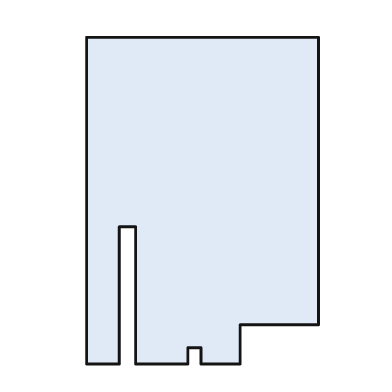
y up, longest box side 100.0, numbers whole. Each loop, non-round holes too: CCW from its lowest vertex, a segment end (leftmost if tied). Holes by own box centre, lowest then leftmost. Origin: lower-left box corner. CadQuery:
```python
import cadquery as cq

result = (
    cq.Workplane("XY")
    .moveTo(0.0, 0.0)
    .lineTo(10.0, 0.0)
    .lineTo(10.0, 42.0)
    .lineTo(15.0, 42.0)
    .lineTo(15.0, 0.0)
    .lineTo(31.0, 0.0)
    .lineTo(31.0, 5.0)
    .lineTo(35.0, 5.0)
    .lineTo(35.0, 0.0)
    .lineTo(47.0, 0.0)
    .lineTo(47.0, 12.0)
    .lineTo(71.0, 12.0)
    .lineTo(71.0, 100.0)
    .lineTo(0.0, 100.0)
    .close()
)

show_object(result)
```